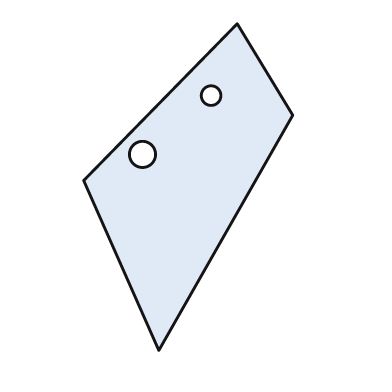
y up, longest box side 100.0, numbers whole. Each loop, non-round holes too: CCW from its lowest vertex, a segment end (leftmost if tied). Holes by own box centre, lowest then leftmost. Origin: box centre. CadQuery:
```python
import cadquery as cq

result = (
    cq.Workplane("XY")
    .moveTo(-9.0, -50.0)
    .lineTo(32.0, 22.0)
    .lineTo(15.0, 50.0)
    .lineTo(-32.0, 2.0)
    .close()
    .moveTo(-14.0, 10.0)
    .circle(4.0)
    .moveTo(7.0, 28.0)
    .circle(3.0)
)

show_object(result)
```